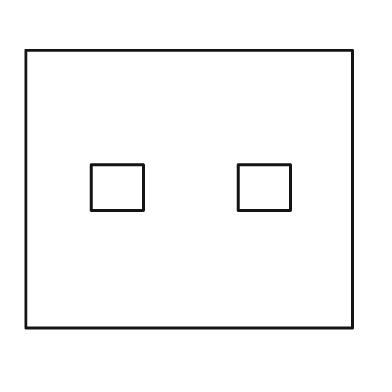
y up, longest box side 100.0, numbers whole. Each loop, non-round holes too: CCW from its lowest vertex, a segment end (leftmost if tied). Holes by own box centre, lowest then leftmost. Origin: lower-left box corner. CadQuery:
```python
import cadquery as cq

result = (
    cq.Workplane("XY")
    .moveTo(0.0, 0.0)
    .lineTo(100.0, 0.0)
    .lineTo(100.0, 85.0)
    .lineTo(0.0, 85.0)
    .close()
    .moveTo(20.0, 36.0)
    .lineTo(36.0, 36.0)
    .lineTo(36.0, 50.0)
    .lineTo(20.0, 50.0)
    .close()
    .moveTo(65.0, 36.0)
    .lineTo(81.0, 36.0)
    .lineTo(81.0, 50.0)
    .lineTo(65.0, 50.0)
    .close()
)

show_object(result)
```